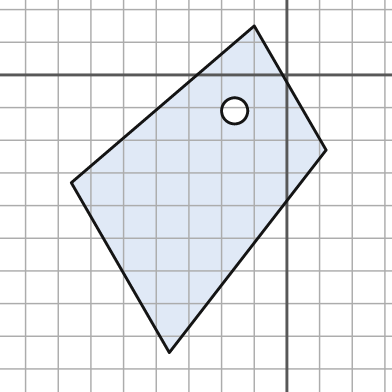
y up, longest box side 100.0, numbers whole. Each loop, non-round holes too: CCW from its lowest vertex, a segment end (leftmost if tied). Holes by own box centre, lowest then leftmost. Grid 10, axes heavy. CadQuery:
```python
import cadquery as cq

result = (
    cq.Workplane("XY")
    .moveTo(-36.0, -85.0)
    .lineTo(12.0, -23.0)
    .lineTo(-10.0, 15.0)
    .lineTo(-66.0, -33.0)
    .close()
    .moveTo(-16.0, -11.0)
    .circle(4.0)
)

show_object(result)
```